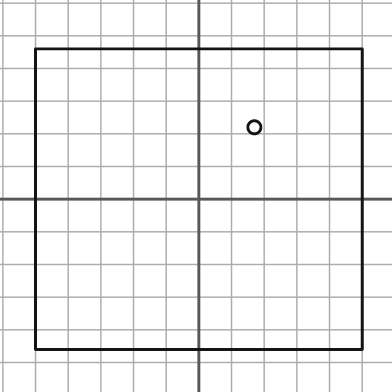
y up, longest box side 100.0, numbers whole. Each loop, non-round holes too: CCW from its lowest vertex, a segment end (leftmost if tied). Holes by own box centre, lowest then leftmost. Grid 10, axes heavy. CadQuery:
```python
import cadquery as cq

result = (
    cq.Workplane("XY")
    .moveTo(-50.0, -46.0)
    .lineTo(50.0, -46.0)
    .lineTo(50.0, 46.0)
    .lineTo(-50.0, 46.0)
    .close()
    .moveTo(17.0, 22.0)
    .circle(2.0)
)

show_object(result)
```